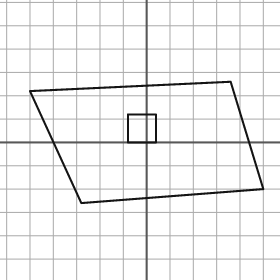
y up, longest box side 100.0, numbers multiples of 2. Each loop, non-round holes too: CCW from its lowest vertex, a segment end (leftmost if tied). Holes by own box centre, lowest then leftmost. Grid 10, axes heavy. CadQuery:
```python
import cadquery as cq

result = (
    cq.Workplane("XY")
    .moveTo(-28.0, -26.0)
    .lineTo(50.0, -20.0)
    .lineTo(36.0, 26.0)
    .lineTo(-50.0, 22.0)
    .close()
    .moveTo(-8.0, 0.0)
    .lineTo(4.0, 0.0)
    .lineTo(4.0, 12.0)
    .lineTo(-8.0, 12.0)
    .close()
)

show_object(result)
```